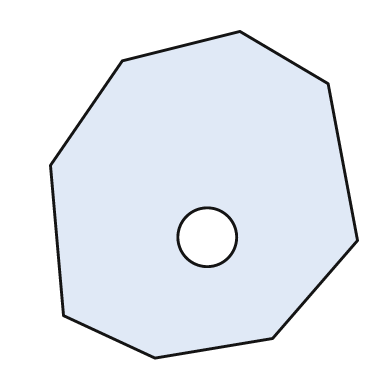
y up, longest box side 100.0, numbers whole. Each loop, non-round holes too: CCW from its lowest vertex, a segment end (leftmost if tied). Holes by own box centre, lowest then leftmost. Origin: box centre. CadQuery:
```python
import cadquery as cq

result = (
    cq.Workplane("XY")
    .moveTo(-15.0, -50.0)
    .lineTo(21.0, -44.0)
    .lineTo(47.0, -14.0)
    .lineTo(38.0, 34.0)
    .lineTo(11.0, 50.0)
    .lineTo(-25.0, 41.0)
    .lineTo(-47.0, 9.0)
    .lineTo(-43.0, -37.0)
    .close()
    .moveTo(1.0, -13.0)
    .circle(9.0)
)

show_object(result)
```